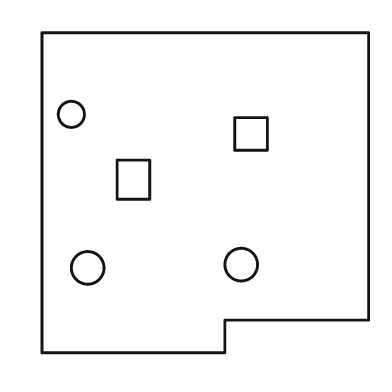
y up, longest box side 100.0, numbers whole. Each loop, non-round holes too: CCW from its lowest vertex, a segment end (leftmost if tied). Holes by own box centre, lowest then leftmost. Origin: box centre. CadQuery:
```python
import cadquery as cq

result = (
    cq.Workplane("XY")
    .moveTo(-50.0, -49.0)
    .lineTo(6.0, -49.0)
    .lineTo(6.0, -39.0)
    .lineTo(50.0, -39.0)
    .lineTo(50.0, 49.0)
    .lineTo(-50.0, 49.0)
    .close()
    .moveTo(-36.0, -23.0)
    .circle(5.0)
    .moveTo(11.0, -22.0)
    .circle(5.0)
    .moveTo(-27.0, -2.0)
    .lineTo(-17.0, -2.0)
    .lineTo(-17.0, 10.0)
    .lineTo(-27.0, 10.0)
    .close()
    .moveTo(9.0, 13.0)
    .lineTo(19.0, 13.0)
    .lineTo(19.0, 23.0)
    .lineTo(9.0, 23.0)
    .close()
    .moveTo(-41.0, 24.0)
    .circle(4.0)
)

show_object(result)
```